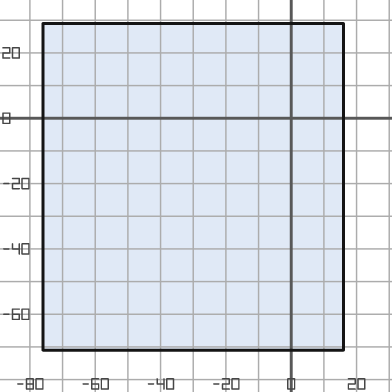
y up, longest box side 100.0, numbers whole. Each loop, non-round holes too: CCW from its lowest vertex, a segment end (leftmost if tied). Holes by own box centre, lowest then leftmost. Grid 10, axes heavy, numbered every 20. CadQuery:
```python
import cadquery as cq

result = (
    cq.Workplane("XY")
    .moveTo(-76.0, -71.0)
    .lineTo(16.0, -71.0)
    .lineTo(16.0, 29.0)
    .lineTo(-76.0, 29.0)
    .close()
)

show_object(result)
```